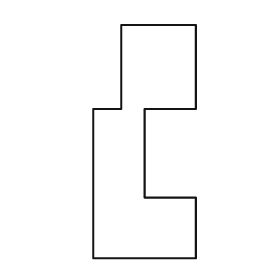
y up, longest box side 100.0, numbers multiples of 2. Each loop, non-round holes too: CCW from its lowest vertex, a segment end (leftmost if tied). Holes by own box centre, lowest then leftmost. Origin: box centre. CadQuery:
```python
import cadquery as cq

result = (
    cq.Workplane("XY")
    .moveTo(-22.0, -50.0)
    .lineTo(22.0, -50.0)
    .lineTo(22.0, -24.0)
    .lineTo(0.0, -24.0)
    .lineTo(0.0, 14.0)
    .lineTo(22.0, 14.0)
    .lineTo(22.0, 50.0)
    .lineTo(-10.0, 50.0)
    .lineTo(-10.0, 14.0)
    .lineTo(-22.0, 14.0)
    .close()
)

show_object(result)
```